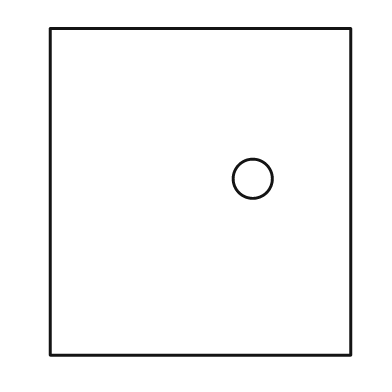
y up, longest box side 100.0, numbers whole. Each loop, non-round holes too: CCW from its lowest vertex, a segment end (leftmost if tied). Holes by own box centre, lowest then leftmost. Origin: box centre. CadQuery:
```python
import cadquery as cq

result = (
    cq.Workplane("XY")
    .moveTo(-46.0, -50.0)
    .lineTo(46.0, -50.0)
    .lineTo(46.0, 50.0)
    .lineTo(-46.0, 50.0)
    .close()
    .moveTo(16.0, 4.0)
    .circle(6.0)
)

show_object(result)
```